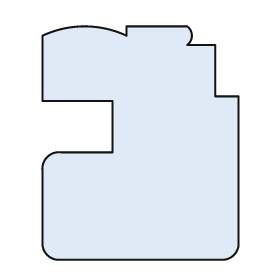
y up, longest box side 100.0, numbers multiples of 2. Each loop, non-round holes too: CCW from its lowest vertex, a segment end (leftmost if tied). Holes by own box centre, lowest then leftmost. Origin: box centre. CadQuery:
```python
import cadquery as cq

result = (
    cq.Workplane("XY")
    .moveTo(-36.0, -50.0)
    .lineTo(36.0, -50.0)
    .threePointArc((40.0, -48.0), (42.0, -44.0))
    .lineTo(42.0, 20.0)
    .lineTo(32.0, 20.0)
    .lineTo(32.0, 42.0)
    .lineTo(20.0, 42.0)
    .threePointArc((22.0, 46.0), (20.0, 50.0))
    .lineTo(-6.0, 50.0)
    .lineTo(-6.0, 46.0)
    .threePointArc((-24.0, 50.0), (-42.0, 46.0))
    .lineTo(-42.0, 18.0)
    .lineTo(-12.0, 18.0)
    .lineTo(-12.0, -4.0)
    .lineTo(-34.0, -4.0)
    .threePointArc((-40.0, -6.0), (-42.0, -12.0))
    .lineTo(-42.0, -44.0)
    .threePointArc((-40.0, -48.0), (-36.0, -50.0))
    .close()
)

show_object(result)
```